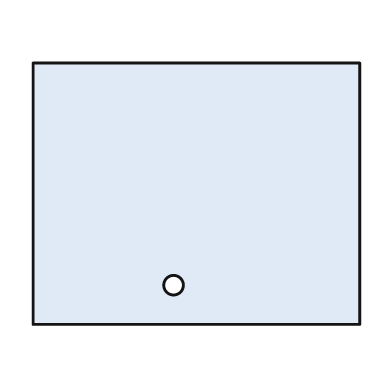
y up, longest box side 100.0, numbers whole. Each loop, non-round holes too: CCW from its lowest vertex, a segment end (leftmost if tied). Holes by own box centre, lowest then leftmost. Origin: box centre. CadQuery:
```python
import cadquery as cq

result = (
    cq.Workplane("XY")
    .moveTo(-50.0, -40.0)
    .lineTo(50.0, -40.0)
    .lineTo(50.0, 40.0)
    .lineTo(-50.0, 40.0)
    .close()
    .moveTo(-7.0, -28.0)
    .circle(3.0)
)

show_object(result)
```